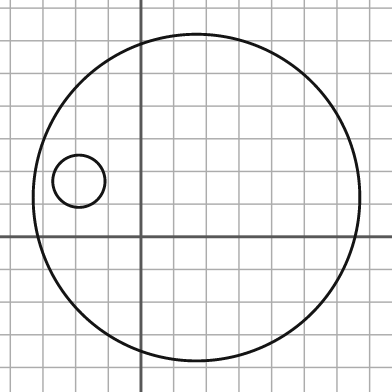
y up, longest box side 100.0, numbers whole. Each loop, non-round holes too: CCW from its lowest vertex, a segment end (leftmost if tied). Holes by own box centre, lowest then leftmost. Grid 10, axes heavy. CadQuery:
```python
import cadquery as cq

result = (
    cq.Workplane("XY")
    .moveTo(17.0, 12.0)
    .circle(50.0)
    .moveTo(-19.0, 17.0)
    .circle(8.0)
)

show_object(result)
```